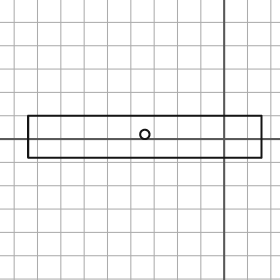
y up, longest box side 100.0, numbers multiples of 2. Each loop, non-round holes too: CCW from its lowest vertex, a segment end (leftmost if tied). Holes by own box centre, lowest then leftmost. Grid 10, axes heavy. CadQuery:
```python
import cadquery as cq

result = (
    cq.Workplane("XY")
    .moveTo(-84.0, -8.0)
    .lineTo(16.0, -8.0)
    .lineTo(16.0, 10.0)
    .lineTo(-84.0, 10.0)
    .close()
    .moveTo(-34.0, 2.0)
    .circle(2.0)
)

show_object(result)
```